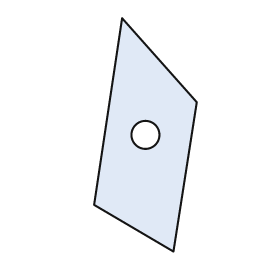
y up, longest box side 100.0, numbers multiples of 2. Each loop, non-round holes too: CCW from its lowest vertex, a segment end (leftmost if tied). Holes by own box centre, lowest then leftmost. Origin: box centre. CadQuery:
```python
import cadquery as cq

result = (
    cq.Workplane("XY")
    .moveTo(12.0, -50.0)
    .lineTo(22.0, 14.0)
    .lineTo(-10.0, 50.0)
    .lineTo(-22.0, -30.0)
    .close()
    .moveTo(0.0, 0.0)
    .circle(6.0)
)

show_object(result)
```